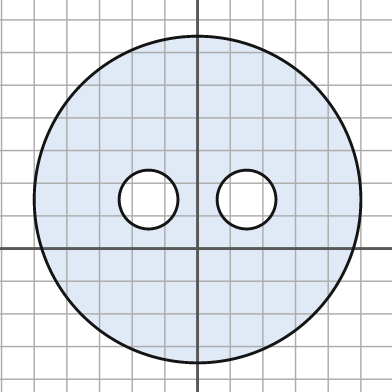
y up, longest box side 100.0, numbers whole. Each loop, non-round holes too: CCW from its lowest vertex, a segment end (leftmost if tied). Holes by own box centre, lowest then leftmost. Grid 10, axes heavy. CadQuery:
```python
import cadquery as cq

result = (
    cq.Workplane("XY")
    .moveTo(0.0, 15.0)
    .circle(50.0)
    .moveTo(-15.0, 15.0)
    .circle(9.0)
    .moveTo(15.0, 15.0)
    .circle(9.0)
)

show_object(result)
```